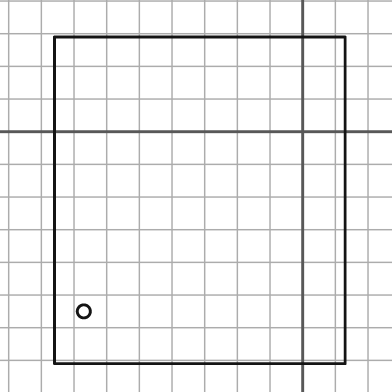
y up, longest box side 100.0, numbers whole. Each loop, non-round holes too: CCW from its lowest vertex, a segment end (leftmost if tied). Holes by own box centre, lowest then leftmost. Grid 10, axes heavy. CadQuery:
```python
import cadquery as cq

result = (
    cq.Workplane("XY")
    .moveTo(-76.0, -71.0)
    .lineTo(13.0, -71.0)
    .lineTo(13.0, 29.0)
    .lineTo(-76.0, 29.0)
    .close()
    .moveTo(-67.0, -55.0)
    .circle(2.0)
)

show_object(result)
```